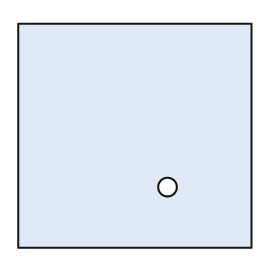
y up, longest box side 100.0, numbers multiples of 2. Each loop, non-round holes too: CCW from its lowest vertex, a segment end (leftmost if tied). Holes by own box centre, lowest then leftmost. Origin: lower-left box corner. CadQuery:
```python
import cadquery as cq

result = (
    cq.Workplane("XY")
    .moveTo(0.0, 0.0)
    .lineTo(100.0, 0.0)
    .lineTo(100.0, 96.0)
    .lineTo(0.0, 96.0)
    .close()
    .moveTo(64.0, 26.0)
    .circle(4.0)
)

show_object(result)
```